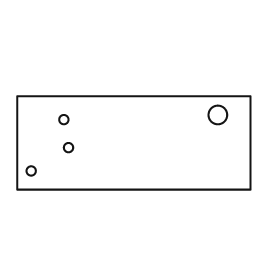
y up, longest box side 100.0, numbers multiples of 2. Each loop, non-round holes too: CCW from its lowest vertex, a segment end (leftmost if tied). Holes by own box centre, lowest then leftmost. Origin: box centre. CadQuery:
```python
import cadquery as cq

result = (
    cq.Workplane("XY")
    .moveTo(-50.0, -20.0)
    .lineTo(50.0, -20.0)
    .lineTo(50.0, 20.0)
    .lineTo(-50.0, 20.0)
    .close()
    .moveTo(-44.0, -12.0)
    .circle(2.0)
    .moveTo(-28.0, -2.0)
    .circle(2.0)
    .moveTo(-30.0, 10.0)
    .circle(2.0)
    .moveTo(36.0, 12.0)
    .circle(4.0)
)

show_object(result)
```